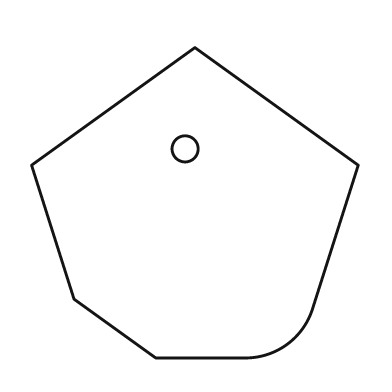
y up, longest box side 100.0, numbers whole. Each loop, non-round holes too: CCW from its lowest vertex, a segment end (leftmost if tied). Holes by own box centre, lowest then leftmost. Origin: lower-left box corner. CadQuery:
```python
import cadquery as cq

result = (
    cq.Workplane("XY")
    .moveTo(38.0, 0.0)
    .lineTo(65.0, 0.0)
    .threePointArc((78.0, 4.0), (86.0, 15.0))
    .lineTo(100.0, 59.0)
    .lineTo(50.0, 95.0)
    .lineTo(0.0, 59.0)
    .lineTo(13.0, 18.0)
    .close()
    .moveTo(47.0, 64.0)
    .circle(4.0)
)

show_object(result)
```